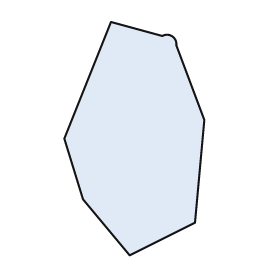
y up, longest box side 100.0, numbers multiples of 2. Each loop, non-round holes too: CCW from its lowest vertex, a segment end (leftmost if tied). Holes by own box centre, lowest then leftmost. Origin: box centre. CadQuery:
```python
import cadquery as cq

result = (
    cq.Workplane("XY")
    .moveTo(-2.0, -50.0)
    .lineTo(26.0, -36.0)
    .lineTo(30.0, 8.0)
    .lineTo(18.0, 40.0)
    .threePointArc((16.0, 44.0), (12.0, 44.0))
    .lineTo(-10.0, 50.0)
    .lineTo(-30.0, 0.0)
    .lineTo(-22.0, -26.0)
    .close()
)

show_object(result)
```